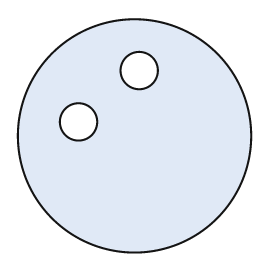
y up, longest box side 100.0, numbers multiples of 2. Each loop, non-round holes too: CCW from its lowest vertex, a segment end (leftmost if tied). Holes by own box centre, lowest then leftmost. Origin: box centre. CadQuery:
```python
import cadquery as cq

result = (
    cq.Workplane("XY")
    .moveTo(0.0, 0.0)
    .circle(50.0)
    .moveTo(-24.0, 6.0)
    .circle(8.0)
    .moveTo(2.0, 28.0)
    .circle(8.0)
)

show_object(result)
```